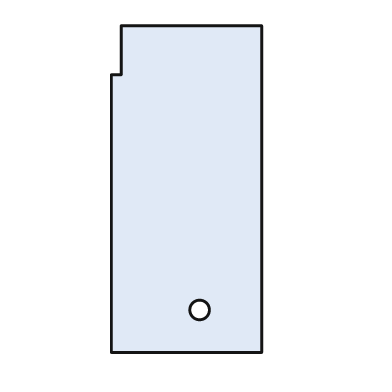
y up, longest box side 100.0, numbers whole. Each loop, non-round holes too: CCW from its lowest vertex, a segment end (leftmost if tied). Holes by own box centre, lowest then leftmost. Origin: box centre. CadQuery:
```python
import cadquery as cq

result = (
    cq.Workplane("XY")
    .moveTo(-23.0, -50.0)
    .lineTo(23.0, -50.0)
    .lineTo(23.0, 50.0)
    .lineTo(-20.0, 50.0)
    .lineTo(-20.0, 35.0)
    .lineTo(-23.0, 35.0)
    .close()
    .moveTo(4.0, -37.0)
    .circle(3.0)
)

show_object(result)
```